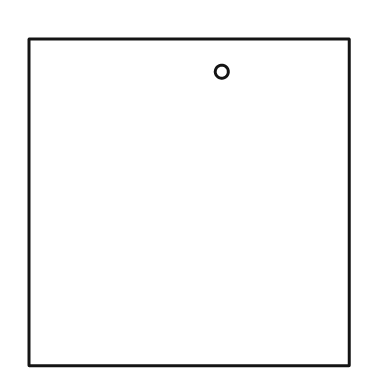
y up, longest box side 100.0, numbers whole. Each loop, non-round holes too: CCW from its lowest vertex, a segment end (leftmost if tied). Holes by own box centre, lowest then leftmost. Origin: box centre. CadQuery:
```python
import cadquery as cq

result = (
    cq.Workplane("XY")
    .moveTo(-49.0, -50.0)
    .lineTo(49.0, -50.0)
    .lineTo(49.0, 50.0)
    .lineTo(-49.0, 50.0)
    .close()
    .moveTo(10.0, 40.0)
    .circle(2.0)
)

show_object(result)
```